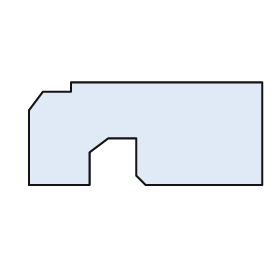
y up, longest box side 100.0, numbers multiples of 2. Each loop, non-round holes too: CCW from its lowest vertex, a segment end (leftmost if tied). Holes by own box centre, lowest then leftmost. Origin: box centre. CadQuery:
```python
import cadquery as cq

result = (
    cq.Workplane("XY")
    .moveTo(-50.0, -22.0)
    .lineTo(-24.0, -22.0)
    .lineTo(-24.0, -8.0)
    .lineTo(-16.0, -2.0)
    .lineTo(-4.0, -2.0)
    .lineTo(-4.0, -18.0)
    .lineTo(0.0, -22.0)
    .lineTo(50.0, -22.0)
    .lineTo(50.0, 22.0)
    .lineTo(-32.0, 22.0)
    .lineTo(-32.0, 18.0)
    .lineTo(-44.0, 18.0)
    .lineTo(-50.0, 10.0)
    .close()
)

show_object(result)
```